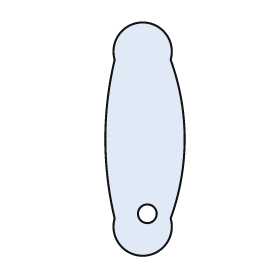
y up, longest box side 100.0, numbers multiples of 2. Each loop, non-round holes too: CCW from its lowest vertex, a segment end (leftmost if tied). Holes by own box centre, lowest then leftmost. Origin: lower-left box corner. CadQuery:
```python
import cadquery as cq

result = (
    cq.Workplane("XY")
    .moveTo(4.0, 16.0)
    .threePointArc((16.0, 0.0), (28.0, 16.0))
    .threePointArc((34.0, 50.0), (28.0, 84.0))
    .threePointArc((16.0, 100.0), (4.0, 84.0))
    .threePointArc((0.0, 50.0), (4.0, 16.0))
    .close()
    .moveTo(18.0, 18.0)
    .circle(4.0)
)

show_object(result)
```